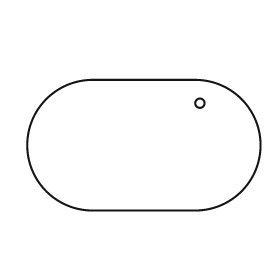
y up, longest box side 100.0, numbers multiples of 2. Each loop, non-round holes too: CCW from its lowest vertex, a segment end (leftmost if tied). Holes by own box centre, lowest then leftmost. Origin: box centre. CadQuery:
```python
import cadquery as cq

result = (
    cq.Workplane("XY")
    .moveTo(-22.0, -28.0)
    .lineTo(22.0, -28.0)
    .threePointArc((50.0, 0.0), (22.0, 28.0))
    .lineTo(-22.0, 28.0)
    .threePointArc((-50.0, 0.0), (-22.0, -28.0))
    .close()
    .moveTo(24.0, 18.0)
    .circle(2.0)
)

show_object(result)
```